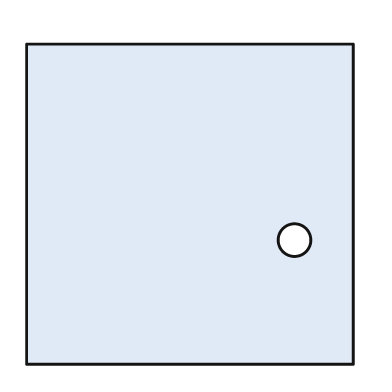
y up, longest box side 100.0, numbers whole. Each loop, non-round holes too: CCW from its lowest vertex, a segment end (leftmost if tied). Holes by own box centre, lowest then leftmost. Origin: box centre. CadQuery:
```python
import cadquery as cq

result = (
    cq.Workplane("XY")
    .moveTo(-50.0, -49.0)
    .lineTo(50.0, -49.0)
    .lineTo(50.0, 49.0)
    .lineTo(-50.0, 49.0)
    .close()
    .moveTo(32.0, -11.0)
    .circle(5.0)
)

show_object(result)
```